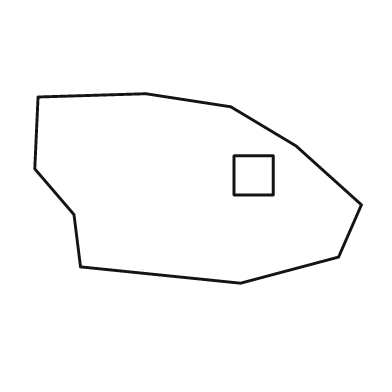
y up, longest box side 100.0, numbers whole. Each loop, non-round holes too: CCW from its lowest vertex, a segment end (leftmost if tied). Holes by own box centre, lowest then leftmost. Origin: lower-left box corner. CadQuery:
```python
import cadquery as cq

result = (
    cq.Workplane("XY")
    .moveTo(63.0, 0.0)
    .lineTo(93.0, 8.0)
    .lineTo(100.0, 24.0)
    .lineTo(80.0, 42.0)
    .lineTo(60.0, 54.0)
    .lineTo(34.0, 58.0)
    .lineTo(1.0, 57.0)
    .lineTo(0.0, 35.0)
    .lineTo(12.0, 21.0)
    .lineTo(14.0, 5.0)
    .close()
    .moveTo(61.0, 27.0)
    .lineTo(73.0, 27.0)
    .lineTo(73.0, 39.0)
    .lineTo(61.0, 39.0)
    .close()
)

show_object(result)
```